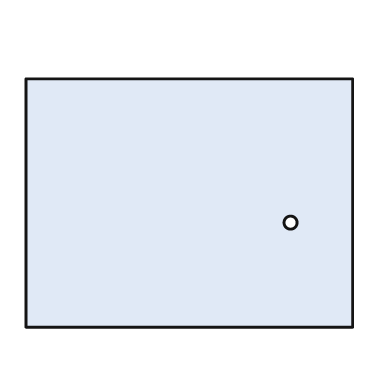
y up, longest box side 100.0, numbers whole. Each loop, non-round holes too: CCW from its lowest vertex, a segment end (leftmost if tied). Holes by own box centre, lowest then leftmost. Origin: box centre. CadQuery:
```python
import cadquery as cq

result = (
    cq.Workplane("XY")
    .moveTo(-50.0, -38.0)
    .lineTo(50.0, -38.0)
    .lineTo(50.0, 38.0)
    .lineTo(-50.0, 38.0)
    .close()
    .moveTo(31.0, -6.0)
    .circle(2.0)
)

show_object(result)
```